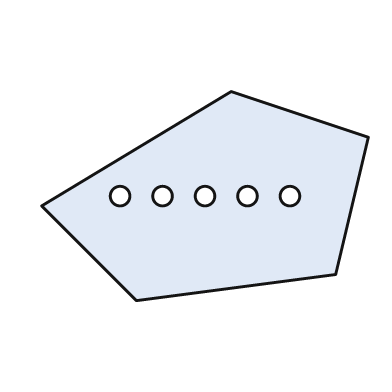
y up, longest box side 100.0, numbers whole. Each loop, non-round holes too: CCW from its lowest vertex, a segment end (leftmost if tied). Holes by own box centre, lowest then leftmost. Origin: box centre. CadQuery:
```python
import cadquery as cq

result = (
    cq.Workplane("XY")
    .moveTo(-21.0, -32.0)
    .lineTo(40.0, -24.0)
    .lineTo(50.0, 18.0)
    .lineTo(8.0, 32.0)
    .lineTo(-50.0, -3.0)
    .close()
    .moveTo(-26.0, 0.0)
    .circle(3.0)
    .moveTo(-13.0, 0.0)
    .circle(3.0)
    .moveTo(0.0, 0.0)
    .circle(3.0)
    .moveTo(13.0, 0.0)
    .circle(3.0)
    .moveTo(26.0, 0.0)
    .circle(3.0)
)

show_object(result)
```